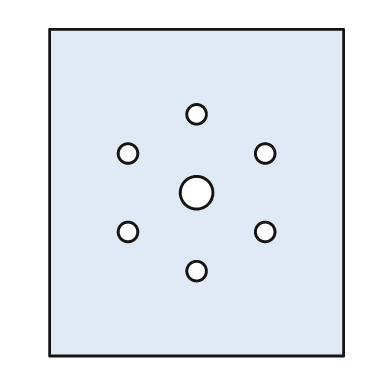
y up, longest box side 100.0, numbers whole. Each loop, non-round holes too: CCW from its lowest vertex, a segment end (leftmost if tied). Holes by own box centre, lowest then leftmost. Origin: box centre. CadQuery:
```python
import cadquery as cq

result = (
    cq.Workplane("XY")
    .moveTo(-45.0, -50.0)
    .lineTo(45.0, -50.0)
    .lineTo(45.0, 50.0)
    .lineTo(-45.0, 50.0)
    .close()
    .moveTo(0.0, -24.0)
    .circle(3.0)
    .moveTo(-21.0, -12.0)
    .circle(3.0)
    .moveTo(21.0, -12.0)
    .circle(3.0)
    .moveTo(0.0, 0.0)
    .circle(5.0)
    .moveTo(-21.0, 12.0)
    .circle(3.0)
    .moveTo(21.0, 12.0)
    .circle(3.0)
    .moveTo(0.0, 24.0)
    .circle(3.0)
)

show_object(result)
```